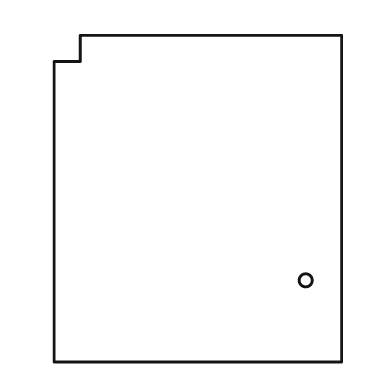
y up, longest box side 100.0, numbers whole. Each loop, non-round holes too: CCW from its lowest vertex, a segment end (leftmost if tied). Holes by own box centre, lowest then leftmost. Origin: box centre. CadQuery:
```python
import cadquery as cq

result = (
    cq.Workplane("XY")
    .moveTo(-44.0, -50.0)
    .lineTo(44.0, -50.0)
    .lineTo(44.0, 50.0)
    .lineTo(-36.0, 50.0)
    .lineTo(-36.0, 42.0)
    .lineTo(-44.0, 42.0)
    .close()
    .moveTo(33.0, -25.0)
    .circle(2.0)
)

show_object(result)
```